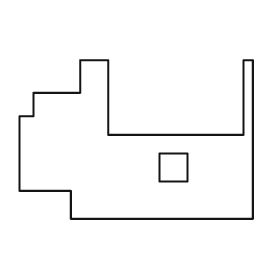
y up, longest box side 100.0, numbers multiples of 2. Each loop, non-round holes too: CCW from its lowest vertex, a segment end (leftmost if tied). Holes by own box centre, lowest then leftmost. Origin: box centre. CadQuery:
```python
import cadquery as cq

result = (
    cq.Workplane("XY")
    .moveTo(-28.0, -34.0)
    .lineTo(50.0, -34.0)
    .lineTo(50.0, 34.0)
    .lineTo(46.0, 34.0)
    .lineTo(46.0, 2.0)
    .lineTo(-12.0, 2.0)
    .lineTo(-12.0, 34.0)
    .lineTo(-24.0, 34.0)
    .lineTo(-24.0, 20.0)
    .lineTo(-44.0, 20.0)
    .lineTo(-44.0, 10.0)
    .lineTo(-50.0, 10.0)
    .lineTo(-50.0, -22.0)
    .lineTo(-28.0, -22.0)
    .close()
    .moveTo(10.0, -18.0)
    .lineTo(22.0, -18.0)
    .lineTo(22.0, -6.0)
    .lineTo(10.0, -6.0)
    .close()
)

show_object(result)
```